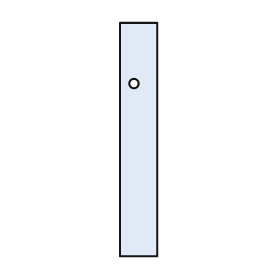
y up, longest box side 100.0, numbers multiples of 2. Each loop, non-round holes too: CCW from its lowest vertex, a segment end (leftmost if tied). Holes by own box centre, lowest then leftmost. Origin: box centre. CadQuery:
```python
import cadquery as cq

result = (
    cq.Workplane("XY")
    .moveTo(-8.0, -50.0)
    .lineTo(8.0, -50.0)
    .lineTo(8.0, 50.0)
    .lineTo(-8.0, 50.0)
    .close()
    .moveTo(-2.0, 24.0)
    .circle(2.0)
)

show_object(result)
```